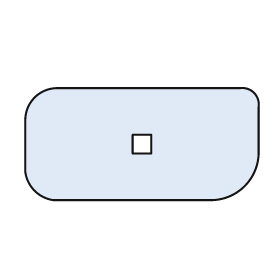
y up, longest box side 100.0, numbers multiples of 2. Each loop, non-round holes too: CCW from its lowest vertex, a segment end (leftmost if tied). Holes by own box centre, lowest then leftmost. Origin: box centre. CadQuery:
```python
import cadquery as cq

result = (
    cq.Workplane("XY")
    .moveTo(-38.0, -24.0)
    .lineTo(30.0, -24.0)
    .threePointArc((44.0, -18.0), (50.0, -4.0))
    .lineTo(50.0, 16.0)
    .threePointArc((48.0, 22.0), (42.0, 24.0))
    .lineTo(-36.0, 24.0)
    .threePointArc((-46.0, 20.0), (-50.0, 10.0))
    .lineTo(-50.0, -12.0)
    .threePointArc((-46.0, -20.0), (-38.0, -24.0))
    .close()
    .moveTo(-4.0, -4.0)
    .lineTo(4.0, -4.0)
    .lineTo(4.0, 4.0)
    .lineTo(-4.0, 4.0)
    .close()
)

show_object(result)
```